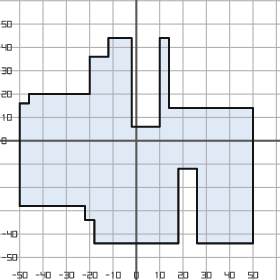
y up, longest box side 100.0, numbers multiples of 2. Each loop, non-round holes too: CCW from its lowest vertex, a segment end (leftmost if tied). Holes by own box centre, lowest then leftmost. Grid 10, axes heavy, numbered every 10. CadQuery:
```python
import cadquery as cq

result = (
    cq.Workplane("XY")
    .moveTo(-18.0, -44.0)
    .lineTo(18.0, -44.0)
    .lineTo(18.0, -12.0)
    .lineTo(26.0, -12.0)
    .lineTo(26.0, -44.0)
    .lineTo(50.0, -44.0)
    .lineTo(50.0, 14.0)
    .lineTo(14.0, 14.0)
    .lineTo(14.0, 44.0)
    .lineTo(10.0, 44.0)
    .lineTo(10.0, 6.0)
    .lineTo(-2.0, 6.0)
    .lineTo(-2.0, 44.0)
    .lineTo(-12.0, 44.0)
    .lineTo(-12.0, 36.0)
    .lineTo(-20.0, 36.0)
    .lineTo(-20.0, 20.0)
    .lineTo(-46.0, 20.0)
    .lineTo(-46.0, 16.0)
    .lineTo(-50.0, 16.0)
    .lineTo(-50.0, -28.0)
    .lineTo(-22.0, -28.0)
    .lineTo(-22.0, -34.0)
    .lineTo(-18.0, -34.0)
    .close()
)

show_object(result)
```